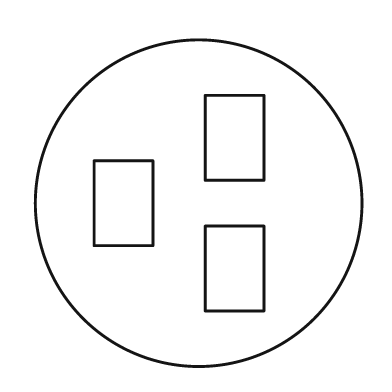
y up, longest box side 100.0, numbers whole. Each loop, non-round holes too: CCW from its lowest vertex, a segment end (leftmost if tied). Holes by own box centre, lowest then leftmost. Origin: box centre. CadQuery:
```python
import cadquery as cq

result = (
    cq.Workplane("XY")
    .moveTo(0.0, 0.0)
    .circle(50.0)
    .moveTo(2.0, -33.0)
    .lineTo(20.0, -33.0)
    .lineTo(20.0, -7.0)
    .lineTo(2.0, -7.0)
    .close()
    .moveTo(-32.0, -13.0)
    .lineTo(-14.0, -13.0)
    .lineTo(-14.0, 13.0)
    .lineTo(-32.0, 13.0)
    .close()
    .moveTo(2.0, 7.0)
    .lineTo(20.0, 7.0)
    .lineTo(20.0, 33.0)
    .lineTo(2.0, 33.0)
    .close()
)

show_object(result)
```